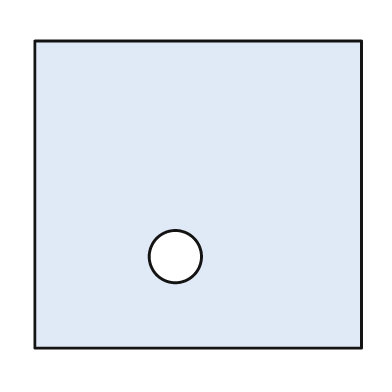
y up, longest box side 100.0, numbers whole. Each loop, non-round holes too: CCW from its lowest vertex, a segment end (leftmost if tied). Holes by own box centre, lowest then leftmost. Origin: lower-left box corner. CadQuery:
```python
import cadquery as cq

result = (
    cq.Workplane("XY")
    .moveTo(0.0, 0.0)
    .lineTo(100.0, 0.0)
    .lineTo(100.0, 94.0)
    .lineTo(0.0, 94.0)
    .close()
    .moveTo(43.0, 28.0)
    .circle(8.0)
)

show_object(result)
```